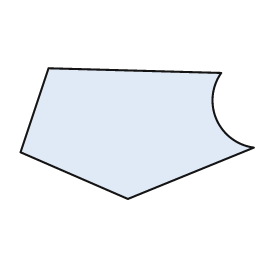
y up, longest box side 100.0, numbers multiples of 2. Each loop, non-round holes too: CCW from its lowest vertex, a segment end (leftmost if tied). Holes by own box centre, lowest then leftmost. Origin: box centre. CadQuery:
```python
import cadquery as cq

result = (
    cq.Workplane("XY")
    .moveTo(-4.0, -28.0)
    .lineTo(50.0, -6.0)
    .threePointArc((34.0, 6.0), (36.0, 26.0))
    .lineTo(-38.0, 28.0)
    .lineTo(-50.0, -8.0)
    .close()
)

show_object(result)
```